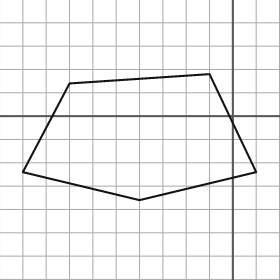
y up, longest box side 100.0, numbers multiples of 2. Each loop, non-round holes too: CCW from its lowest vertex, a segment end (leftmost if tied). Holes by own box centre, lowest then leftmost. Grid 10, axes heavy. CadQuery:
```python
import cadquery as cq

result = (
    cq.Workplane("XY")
    .moveTo(-40.0, -36.0)
    .lineTo(10.0, -24.0)
    .lineTo(-10.0, 18.0)
    .lineTo(-70.0, 14.0)
    .lineTo(-90.0, -24.0)
    .close()
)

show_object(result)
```